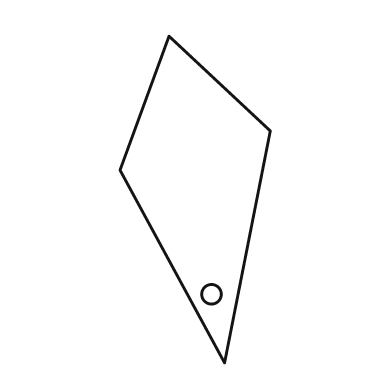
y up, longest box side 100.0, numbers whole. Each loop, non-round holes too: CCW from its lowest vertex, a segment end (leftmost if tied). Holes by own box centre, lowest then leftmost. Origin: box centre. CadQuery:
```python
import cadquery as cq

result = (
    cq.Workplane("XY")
    .moveTo(9.0, -50.0)
    .lineTo(23.0, 21.0)
    .lineTo(-8.0, 50.0)
    .lineTo(-23.0, 9.0)
    .close()
    .moveTo(5.0, -29.0)
    .circle(3.0)
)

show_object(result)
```